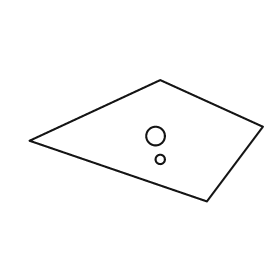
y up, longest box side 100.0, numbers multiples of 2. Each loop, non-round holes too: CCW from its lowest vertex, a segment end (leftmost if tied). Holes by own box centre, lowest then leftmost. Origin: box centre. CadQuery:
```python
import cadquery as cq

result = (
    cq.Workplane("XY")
    .moveTo(26.0, -26.0)
    .lineTo(50.0, 6.0)
    .lineTo(6.0, 26.0)
    .lineTo(-50.0, 0.0)
    .close()
    .moveTo(6.0, -8.0)
    .circle(2.0)
    .moveTo(4.0, 2.0)
    .circle(4.0)
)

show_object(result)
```